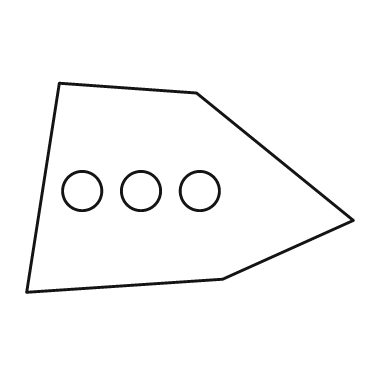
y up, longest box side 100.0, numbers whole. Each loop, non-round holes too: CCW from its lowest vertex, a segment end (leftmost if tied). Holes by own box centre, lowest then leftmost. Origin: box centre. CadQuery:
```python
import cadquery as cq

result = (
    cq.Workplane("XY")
    .moveTo(-50.0, -32.0)
    .lineTo(10.0, -28.0)
    .lineTo(50.0, -10.0)
    .lineTo(2.0, 29.0)
    .lineTo(-40.0, 32.0)
    .close()
    .moveTo(-33.0, -1.0)
    .circle(6.0)
    .moveTo(-15.0, -1.0)
    .circle(6.0)
    .moveTo(3.0, -1.0)
    .circle(6.0)
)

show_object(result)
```